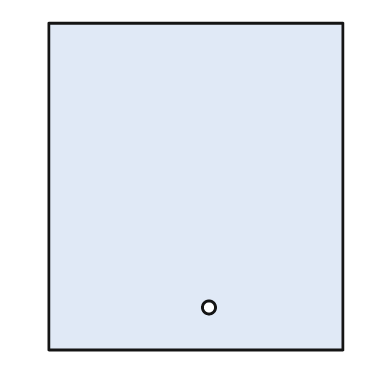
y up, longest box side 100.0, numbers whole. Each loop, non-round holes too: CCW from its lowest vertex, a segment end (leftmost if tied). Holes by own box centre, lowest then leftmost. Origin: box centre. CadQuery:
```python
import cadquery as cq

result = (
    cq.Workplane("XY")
    .moveTo(-45.0, -50.0)
    .lineTo(45.0, -50.0)
    .lineTo(45.0, 50.0)
    .lineTo(-45.0, 50.0)
    .close()
    .moveTo(4.0, -37.0)
    .circle(2.0)
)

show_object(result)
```